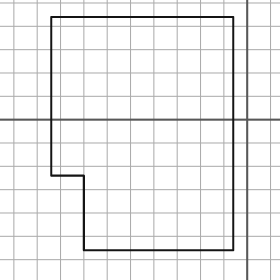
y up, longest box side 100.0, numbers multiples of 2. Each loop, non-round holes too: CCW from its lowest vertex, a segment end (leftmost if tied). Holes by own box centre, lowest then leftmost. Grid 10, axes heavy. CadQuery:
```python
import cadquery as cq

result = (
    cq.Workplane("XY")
    .moveTo(-70.0, -56.0)
    .lineTo(-6.0, -56.0)
    .lineTo(-6.0, 44.0)
    .lineTo(-84.0, 44.0)
    .lineTo(-84.0, -24.0)
    .lineTo(-70.0, -24.0)
    .close()
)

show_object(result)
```